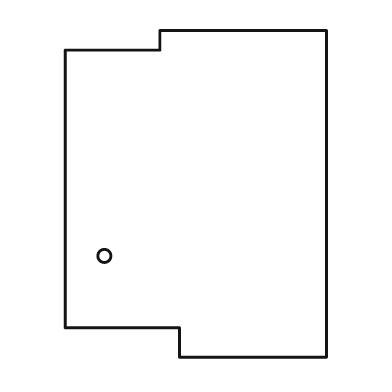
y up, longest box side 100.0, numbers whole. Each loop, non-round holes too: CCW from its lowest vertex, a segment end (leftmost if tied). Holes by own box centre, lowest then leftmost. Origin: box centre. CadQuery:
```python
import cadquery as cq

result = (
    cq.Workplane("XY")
    .moveTo(-5.0, -50.0)
    .lineTo(40.0, -50.0)
    .lineTo(40.0, 50.0)
    .lineTo(-11.0, 50.0)
    .lineTo(-11.0, 44.0)
    .lineTo(-40.0, 44.0)
    .lineTo(-40.0, -41.0)
    .lineTo(-5.0, -41.0)
    .close()
    .moveTo(-28.0, -19.0)
    .circle(2.0)
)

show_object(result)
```